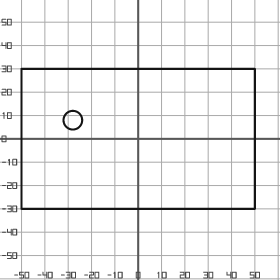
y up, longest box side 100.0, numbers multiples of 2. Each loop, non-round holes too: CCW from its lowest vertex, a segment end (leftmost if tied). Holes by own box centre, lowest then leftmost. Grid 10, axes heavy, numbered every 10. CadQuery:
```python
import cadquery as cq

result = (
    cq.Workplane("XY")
    .moveTo(-50.0, -30.0)
    .lineTo(50.0, -30.0)
    .lineTo(50.0, 30.0)
    .lineTo(-50.0, 30.0)
    .close()
    .moveTo(-28.0, 8.0)
    .circle(4.0)
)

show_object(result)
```